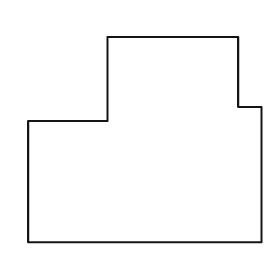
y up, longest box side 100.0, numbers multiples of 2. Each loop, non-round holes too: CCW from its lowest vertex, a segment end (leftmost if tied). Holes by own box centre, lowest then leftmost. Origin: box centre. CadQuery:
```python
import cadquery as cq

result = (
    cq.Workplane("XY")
    .moveTo(-50.0, -44.0)
    .lineTo(50.0, -44.0)
    .lineTo(50.0, 14.0)
    .lineTo(40.0, 14.0)
    .lineTo(40.0, 44.0)
    .lineTo(-16.0, 44.0)
    .lineTo(-16.0, 8.0)
    .lineTo(-50.0, 8.0)
    .close()
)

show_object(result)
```